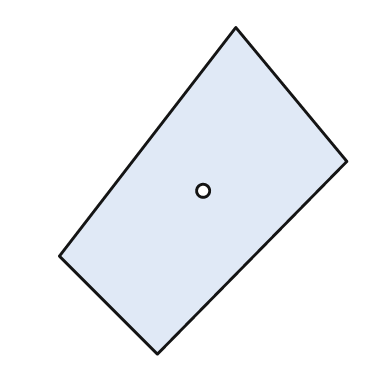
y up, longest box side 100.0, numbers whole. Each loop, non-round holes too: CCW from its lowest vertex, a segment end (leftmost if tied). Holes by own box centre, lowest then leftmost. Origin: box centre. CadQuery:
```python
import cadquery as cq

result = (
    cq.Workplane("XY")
    .moveTo(-14.0, -50.0)
    .lineTo(44.0, 9.0)
    .lineTo(10.0, 50.0)
    .lineTo(-44.0, -20.0)
    .close()
    .moveTo(0.0, 0.0)
    .circle(2.0)
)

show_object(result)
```